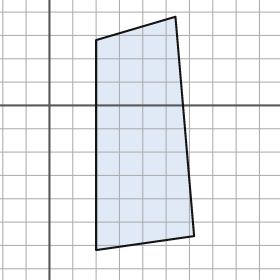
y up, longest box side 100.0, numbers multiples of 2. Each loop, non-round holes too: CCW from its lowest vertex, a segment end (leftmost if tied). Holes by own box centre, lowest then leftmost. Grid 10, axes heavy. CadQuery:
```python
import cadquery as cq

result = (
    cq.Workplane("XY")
    .moveTo(20.0, -62.0)
    .lineTo(62.0, -56.0)
    .lineTo(54.0, 38.0)
    .lineTo(20.0, 28.0)
    .close()
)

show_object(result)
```